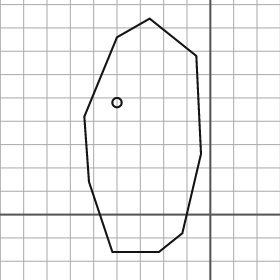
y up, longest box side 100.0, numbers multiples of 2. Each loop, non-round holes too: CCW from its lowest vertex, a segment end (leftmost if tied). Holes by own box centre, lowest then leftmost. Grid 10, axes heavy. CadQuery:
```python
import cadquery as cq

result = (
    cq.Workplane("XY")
    .moveTo(-42.0, -16.0)
    .lineTo(-22.0, -16.0)
    .lineTo(-12.0, -8.0)
    .lineTo(-4.0, 26.0)
    .lineTo(-6.0, 68.0)
    .lineTo(-26.0, 84.0)
    .lineTo(-40.0, 76.0)
    .lineTo(-54.0, 42.0)
    .lineTo(-52.0, 14.0)
    .close()
    .moveTo(-40.0, 48.0)
    .circle(2.0)
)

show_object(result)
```